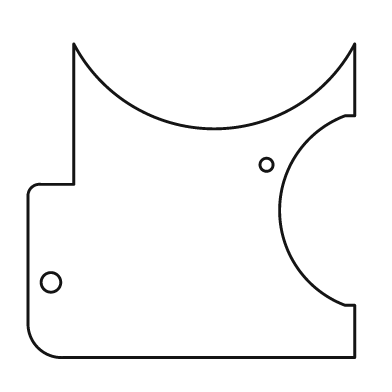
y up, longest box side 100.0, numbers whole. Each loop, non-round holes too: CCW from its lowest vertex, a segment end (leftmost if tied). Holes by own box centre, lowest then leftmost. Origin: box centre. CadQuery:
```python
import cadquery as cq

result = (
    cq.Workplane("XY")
    .moveTo(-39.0, -48.0)
    .lineTo(50.0, -48.0)
    .lineTo(50.0, -32.0)
    .lineTo(47.0, -32.0)
    .threePointArc((27.0, -3.0), (47.0, 26.0))
    .lineTo(50.0, 26.0)
    .lineTo(50.0, 48.0)
    .threePointArc((7.0, 22.0), (-36.0, 48.0))
    .lineTo(-36.0, 5.0)
    .lineTo(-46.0, 5.0)
    .threePointArc((-49.0, 4.0), (-50.0, 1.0))
    .lineTo(-50.0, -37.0)
    .threePointArc((-47.0, -45.0), (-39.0, -48.0))
    .close()
    .moveTo(-43.0, -25.0)
    .circle(3.0)
    .moveTo(23.0, 11.0)
    .circle(2.0)
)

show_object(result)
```